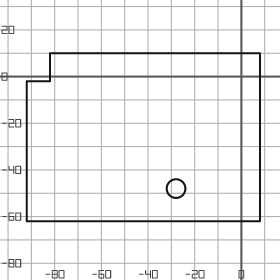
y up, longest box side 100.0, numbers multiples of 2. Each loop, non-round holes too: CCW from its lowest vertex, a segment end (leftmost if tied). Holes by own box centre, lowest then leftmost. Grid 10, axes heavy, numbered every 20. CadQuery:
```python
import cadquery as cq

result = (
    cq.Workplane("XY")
    .moveTo(-92.0, -62.0)
    .lineTo(8.0, -62.0)
    .lineTo(8.0, 10.0)
    .lineTo(-82.0, 10.0)
    .lineTo(-82.0, -2.0)
    .lineTo(-92.0, -2.0)
    .close()
    .moveTo(-28.0, -48.0)
    .circle(4.0)
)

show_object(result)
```